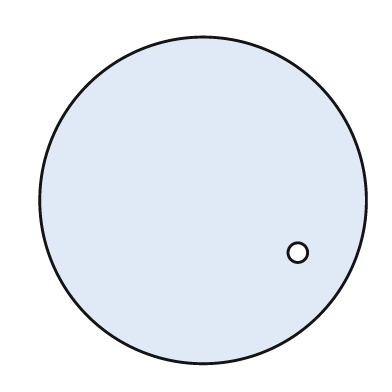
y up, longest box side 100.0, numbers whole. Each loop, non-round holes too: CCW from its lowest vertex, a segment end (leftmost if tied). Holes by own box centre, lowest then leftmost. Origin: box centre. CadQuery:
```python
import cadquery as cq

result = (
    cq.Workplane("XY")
    .moveTo(0.0, 0.0)
    .circle(50.0)
    .moveTo(29.0, -16.0)
    .circle(3.0)
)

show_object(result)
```